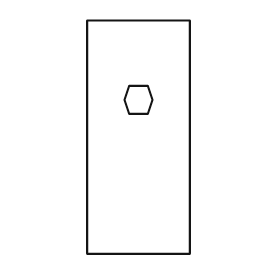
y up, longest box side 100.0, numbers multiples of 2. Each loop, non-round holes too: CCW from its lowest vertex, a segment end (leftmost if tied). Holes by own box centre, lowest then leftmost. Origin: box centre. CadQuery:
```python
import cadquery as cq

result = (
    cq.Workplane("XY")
    .moveTo(-22.0, -50.0)
    .lineTo(22.0, -50.0)
    .lineTo(22.0, 50.0)
    .lineTo(-22.0, 50.0)
    .close()
    .moveTo(-4.0, 10.0)
    .lineTo(4.0, 10.0)
    .lineTo(6.0, 16.0)
    .lineTo(4.0, 22.0)
    .lineTo(-4.0, 22.0)
    .lineTo(-6.0, 16.0)
    .close()
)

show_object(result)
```